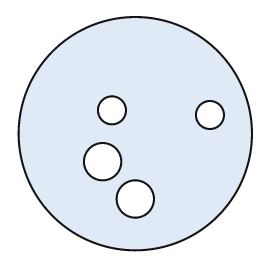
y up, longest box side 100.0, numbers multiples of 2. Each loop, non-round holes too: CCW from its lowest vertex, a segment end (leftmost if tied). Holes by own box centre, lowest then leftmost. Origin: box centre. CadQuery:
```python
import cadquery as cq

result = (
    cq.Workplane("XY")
    .moveTo(0.0, 0.0)
    .circle(50.0)
    .moveTo(0.0, -28.0)
    .circle(8.0)
    .moveTo(-14.0, -12.0)
    .circle(8.0)
    .moveTo(32.0, 8.0)
    .circle(6.0)
    .moveTo(-10.0, 10.0)
    .circle(6.0)
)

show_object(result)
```